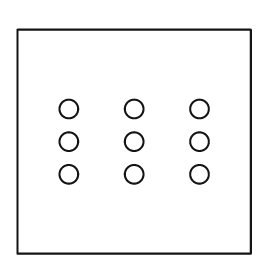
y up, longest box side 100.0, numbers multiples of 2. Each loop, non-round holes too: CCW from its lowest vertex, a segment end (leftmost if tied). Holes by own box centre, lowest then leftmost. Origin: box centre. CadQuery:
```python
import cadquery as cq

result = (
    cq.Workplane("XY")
    .moveTo(-50.0, -48.0)
    .lineTo(50.0, -48.0)
    .lineTo(50.0, 48.0)
    .lineTo(-50.0, 48.0)
    .close()
    .moveTo(-28.0, -14.0)
    .circle(4.0)
    .moveTo(0.0, -14.0)
    .circle(4.0)
    .moveTo(28.0, -14.0)
    .circle(4.0)
    .moveTo(-28.0, 0.0)
    .circle(4.0)
    .moveTo(0.0, 0.0)
    .circle(4.0)
    .moveTo(28.0, 0.0)
    .circle(4.0)
    .moveTo(-28.0, 14.0)
    .circle(4.0)
    .moveTo(0.0, 14.0)
    .circle(4.0)
    .moveTo(28.0, 14.0)
    .circle(4.0)
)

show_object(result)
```